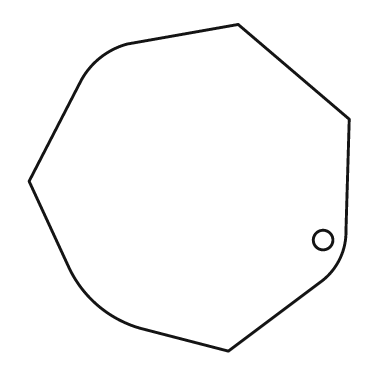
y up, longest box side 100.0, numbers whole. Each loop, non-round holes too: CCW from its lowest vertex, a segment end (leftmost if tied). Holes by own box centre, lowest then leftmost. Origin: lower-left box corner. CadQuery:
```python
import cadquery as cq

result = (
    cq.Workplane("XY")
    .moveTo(61.0, 0.0)
    .lineTo(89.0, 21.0)
    .threePointArc((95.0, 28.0), (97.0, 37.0))
    .lineTo(98.0, 71.0)
    .lineTo(64.0, 100.0)
    .lineTo(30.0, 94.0)
    .threePointArc((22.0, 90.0), (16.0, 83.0))
    .lineTo(0.0, 52.0)
    .lineTo(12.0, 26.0)
    .threePointArc((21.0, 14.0), (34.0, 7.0))
    .close()
    .moveTo(90.0, 34.0)
    .circle(3.0)
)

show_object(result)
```